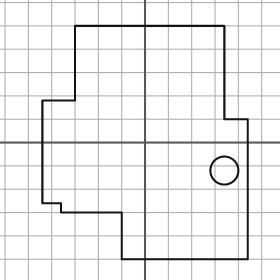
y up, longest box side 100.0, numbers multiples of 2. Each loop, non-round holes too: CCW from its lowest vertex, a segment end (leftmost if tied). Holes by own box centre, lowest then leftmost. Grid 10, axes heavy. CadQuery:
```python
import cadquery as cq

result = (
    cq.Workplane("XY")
    .moveTo(-10.0, -50.0)
    .lineTo(44.0, -50.0)
    .lineTo(44.0, 10.0)
    .lineTo(34.0, 10.0)
    .lineTo(34.0, 50.0)
    .lineTo(-30.0, 50.0)
    .lineTo(-30.0, 18.0)
    .lineTo(-44.0, 18.0)
    .lineTo(-44.0, -26.0)
    .lineTo(-36.0, -26.0)
    .lineTo(-36.0, -30.0)
    .lineTo(-10.0, -30.0)
    .close()
    .moveTo(34.0, -12.0)
    .circle(6.0)
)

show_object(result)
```